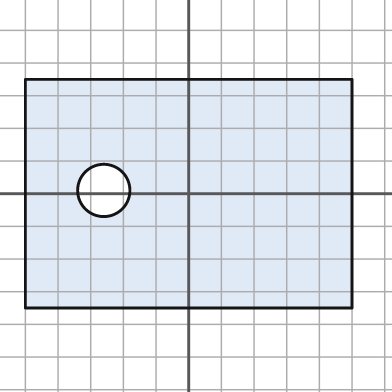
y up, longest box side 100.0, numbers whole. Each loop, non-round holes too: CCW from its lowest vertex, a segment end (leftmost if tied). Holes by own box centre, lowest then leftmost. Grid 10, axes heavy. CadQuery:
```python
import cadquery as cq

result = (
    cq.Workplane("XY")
    .moveTo(-50.0, -35.0)
    .lineTo(50.0, -35.0)
    .lineTo(50.0, 35.0)
    .lineTo(-50.0, 35.0)
    .close()
    .moveTo(-26.0, 1.0)
    .circle(8.0)
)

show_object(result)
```